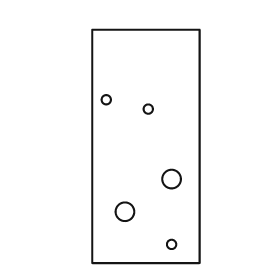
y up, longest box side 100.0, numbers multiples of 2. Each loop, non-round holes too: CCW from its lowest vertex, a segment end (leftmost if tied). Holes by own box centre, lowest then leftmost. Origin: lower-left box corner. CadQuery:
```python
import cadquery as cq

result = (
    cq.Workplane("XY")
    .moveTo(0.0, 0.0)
    .lineTo(46.0, 0.0)
    .lineTo(46.0, 100.0)
    .lineTo(0.0, 100.0)
    .close()
    .moveTo(34.0, 8.0)
    .circle(2.0)
    .moveTo(14.0, 22.0)
    .circle(4.0)
    .moveTo(34.0, 36.0)
    .circle(4.0)
    .moveTo(24.0, 66.0)
    .circle(2.0)
    .moveTo(6.0, 70.0)
    .circle(2.0)
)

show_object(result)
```